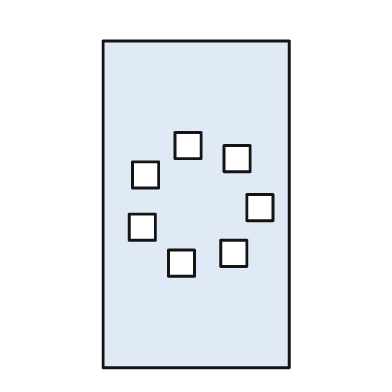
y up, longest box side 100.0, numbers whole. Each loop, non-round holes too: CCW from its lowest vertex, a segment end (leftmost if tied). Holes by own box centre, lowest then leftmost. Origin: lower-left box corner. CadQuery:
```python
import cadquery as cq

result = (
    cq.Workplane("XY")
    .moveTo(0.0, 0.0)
    .lineTo(57.0, 0.0)
    .lineTo(57.0, 100.0)
    .lineTo(0.0, 100.0)
    .close()
    .moveTo(20.0, 28.0)
    .lineTo(28.0, 28.0)
    .lineTo(28.0, 36.0)
    .lineTo(20.0, 36.0)
    .close()
    .moveTo(36.0, 31.0)
    .lineTo(44.0, 31.0)
    .lineTo(44.0, 39.0)
    .lineTo(36.0, 39.0)
    .close()
    .moveTo(8.0, 39.0)
    .lineTo(16.0, 39.0)
    .lineTo(16.0, 47.0)
    .lineTo(8.0, 47.0)
    .close()
    .moveTo(44.0, 45.0)
    .lineTo(52.0, 45.0)
    .lineTo(52.0, 53.0)
    .lineTo(44.0, 53.0)
    .close()
    .moveTo(9.0, 55.0)
    .lineTo(17.0, 55.0)
    .lineTo(17.0, 63.0)
    .lineTo(9.0, 63.0)
    .close()
    .moveTo(37.0, 60.0)
    .lineTo(45.0, 60.0)
    .lineTo(45.0, 68.0)
    .lineTo(37.0, 68.0)
    .close()
    .moveTo(22.0, 64.0)
    .lineTo(30.0, 64.0)
    .lineTo(30.0, 72.0)
    .lineTo(22.0, 72.0)
    .close()
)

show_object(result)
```